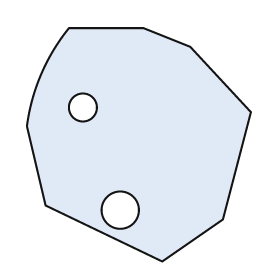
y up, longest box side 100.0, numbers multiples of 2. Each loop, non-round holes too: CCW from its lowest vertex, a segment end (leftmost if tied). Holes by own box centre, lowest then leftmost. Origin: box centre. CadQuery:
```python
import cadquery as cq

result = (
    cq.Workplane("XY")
    .moveTo(10.0, -50.0)
    .lineTo(36.0, -32.0)
    .lineTo(48.0, 14.0)
    .lineTo(22.0, 42.0)
    .lineTo(2.0, 50.0)
    .lineTo(-30.0, 50.0)
    .threePointArc((-42.0, 30.0), (-48.0, 8.0))
    .lineTo(-40.0, -26.0)
    .close()
    .moveTo(-8.0, -28.0)
    .circle(8.0)
    .moveTo(-24.0, 16.0)
    .circle(6.0)
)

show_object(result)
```